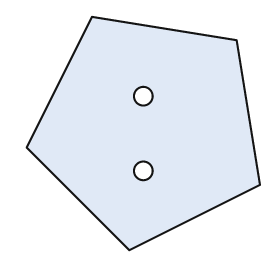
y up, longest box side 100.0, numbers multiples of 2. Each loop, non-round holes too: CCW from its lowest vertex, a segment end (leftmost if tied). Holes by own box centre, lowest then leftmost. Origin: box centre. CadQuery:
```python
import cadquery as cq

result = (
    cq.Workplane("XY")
    .moveTo(-6.0, -50.0)
    .lineTo(50.0, -22.0)
    .lineTo(40.0, 40.0)
    .lineTo(-22.0, 50.0)
    .lineTo(-50.0, -6.0)
    .close()
    .moveTo(0.0, -16.0)
    .circle(4.0)
    .moveTo(0.0, 16.0)
    .circle(4.0)
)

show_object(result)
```